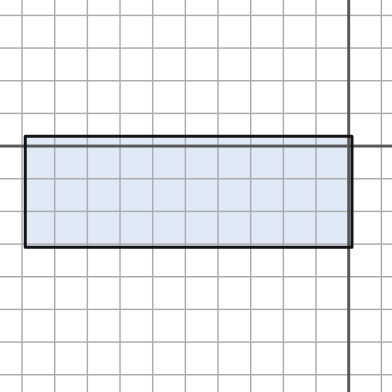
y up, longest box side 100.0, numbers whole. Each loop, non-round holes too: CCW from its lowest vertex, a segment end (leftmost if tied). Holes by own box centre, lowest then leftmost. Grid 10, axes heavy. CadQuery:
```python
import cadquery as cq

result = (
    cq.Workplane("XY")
    .moveTo(-99.0, -31.0)
    .lineTo(1.0, -31.0)
    .lineTo(1.0, 3.0)
    .lineTo(-99.0, 3.0)
    .close()
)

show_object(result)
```